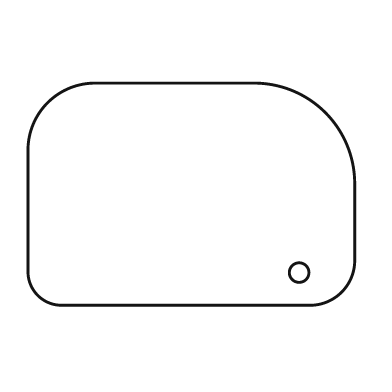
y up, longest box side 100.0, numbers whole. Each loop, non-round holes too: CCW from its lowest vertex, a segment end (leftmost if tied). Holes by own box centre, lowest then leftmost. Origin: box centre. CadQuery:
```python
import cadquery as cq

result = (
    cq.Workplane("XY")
    .moveTo(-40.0, -34.0)
    .lineTo(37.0, -34.0)
    .threePointArc((46.0, -30.0), (50.0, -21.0))
    .lineTo(50.0, 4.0)
    .threePointArc((41.0, 25.0), (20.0, 34.0))
    .lineTo(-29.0, 34.0)
    .threePointArc((-44.0, 28.0), (-50.0, 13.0))
    .lineTo(-50.0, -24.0)
    .threePointArc((-47.0, -31.0), (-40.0, -34.0))
    .close()
    .moveTo(33.0, -24.0)
    .circle(3.0)
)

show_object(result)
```